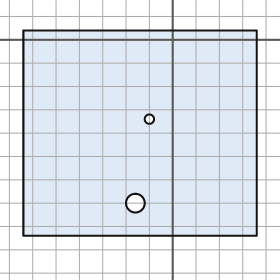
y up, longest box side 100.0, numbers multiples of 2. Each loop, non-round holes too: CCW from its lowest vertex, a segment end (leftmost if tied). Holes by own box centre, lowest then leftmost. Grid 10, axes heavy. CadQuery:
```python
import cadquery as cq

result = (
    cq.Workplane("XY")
    .moveTo(-64.0, -84.0)
    .lineTo(36.0, -84.0)
    .lineTo(36.0, 4.0)
    .lineTo(-64.0, 4.0)
    .close()
    .moveTo(-16.0, -70.0)
    .circle(4.0)
    .moveTo(-10.0, -34.0)
    .circle(2.0)
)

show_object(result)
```